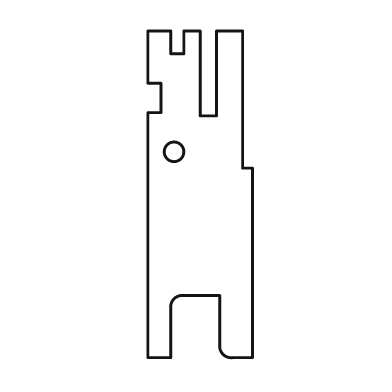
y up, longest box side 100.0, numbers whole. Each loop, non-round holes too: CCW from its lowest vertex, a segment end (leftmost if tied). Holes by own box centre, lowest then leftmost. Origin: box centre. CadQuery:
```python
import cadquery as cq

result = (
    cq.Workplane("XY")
    .moveTo(-16.0, -50.0)
    .lineTo(-9.0, -50.0)
    .lineTo(-9.0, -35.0)
    .threePointArc((-8.0, -32.0), (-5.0, -31.0))
    .lineTo(6.0, -31.0)
    .lineTo(6.0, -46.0)
    .threePointArc((7.0, -49.0), (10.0, -50.0))
    .lineTo(16.0, -50.0)
    .lineTo(16.0, 8.0)
    .lineTo(13.0, 8.0)
    .lineTo(13.0, 50.0)
    .lineTo(5.0, 50.0)
    .lineTo(5.0, 24.0)
    .lineTo(0.0, 24.0)
    .lineTo(0.0, 50.0)
    .lineTo(-5.0, 50.0)
    .lineTo(-5.0, 43.0)
    .lineTo(-9.0, 43.0)
    .lineTo(-9.0, 50.0)
    .lineTo(-16.0, 50.0)
    .lineTo(-16.0, 34.0)
    .lineTo(-12.0, 34.0)
    .lineTo(-12.0, 25.0)
    .lineTo(-16.0, 25.0)
    .close()
    .moveTo(-8.0, 13.0)
    .circle(3.0)
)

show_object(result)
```